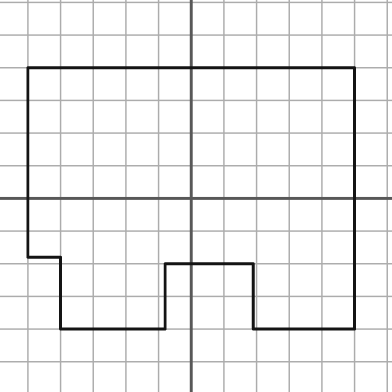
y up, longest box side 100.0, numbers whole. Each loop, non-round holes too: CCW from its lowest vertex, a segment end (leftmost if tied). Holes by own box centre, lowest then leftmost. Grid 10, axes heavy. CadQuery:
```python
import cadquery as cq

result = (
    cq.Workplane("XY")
    .moveTo(-40.0, -40.0)
    .lineTo(-8.0, -40.0)
    .lineTo(-8.0, -20.0)
    .lineTo(19.0, -20.0)
    .lineTo(19.0, -40.0)
    .lineTo(50.0, -40.0)
    .lineTo(50.0, 40.0)
    .lineTo(-50.0, 40.0)
    .lineTo(-50.0, -18.0)
    .lineTo(-40.0, -18.0)
    .close()
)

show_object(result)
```